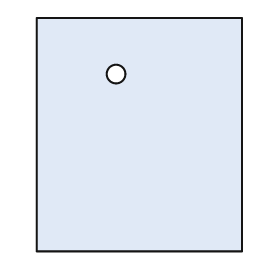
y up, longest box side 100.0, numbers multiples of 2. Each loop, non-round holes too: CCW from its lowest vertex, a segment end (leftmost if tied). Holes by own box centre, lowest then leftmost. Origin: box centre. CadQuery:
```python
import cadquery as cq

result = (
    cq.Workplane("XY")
    .moveTo(-44.0, -50.0)
    .lineTo(44.0, -50.0)
    .lineTo(44.0, 50.0)
    .lineTo(-44.0, 50.0)
    .close()
    .moveTo(-10.0, 26.0)
    .circle(4.0)
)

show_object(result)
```